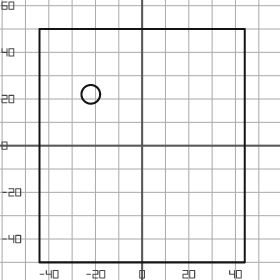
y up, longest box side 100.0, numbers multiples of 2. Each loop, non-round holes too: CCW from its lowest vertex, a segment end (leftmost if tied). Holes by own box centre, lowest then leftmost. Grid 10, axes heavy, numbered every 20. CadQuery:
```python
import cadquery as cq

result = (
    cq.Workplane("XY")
    .moveTo(-44.0, -50.0)
    .lineTo(44.0, -50.0)
    .lineTo(44.0, 50.0)
    .lineTo(-44.0, 50.0)
    .close()
    .moveTo(-22.0, 22.0)
    .circle(4.0)
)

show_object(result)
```